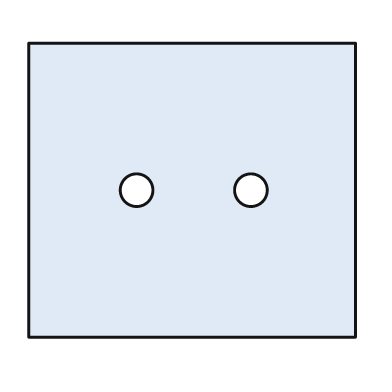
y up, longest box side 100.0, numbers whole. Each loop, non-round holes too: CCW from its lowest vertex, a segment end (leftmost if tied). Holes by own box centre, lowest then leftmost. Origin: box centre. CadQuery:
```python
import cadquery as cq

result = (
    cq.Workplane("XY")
    .moveTo(-50.0, -45.0)
    .lineTo(50.0, -45.0)
    .lineTo(50.0, 45.0)
    .lineTo(-50.0, 45.0)
    .close()
    .moveTo(-17.0, 0.0)
    .circle(5.0)
    .moveTo(18.0, 0.0)
    .circle(5.0)
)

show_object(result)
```